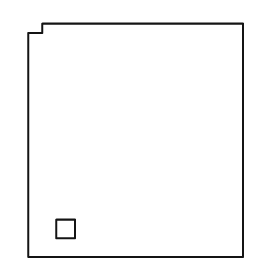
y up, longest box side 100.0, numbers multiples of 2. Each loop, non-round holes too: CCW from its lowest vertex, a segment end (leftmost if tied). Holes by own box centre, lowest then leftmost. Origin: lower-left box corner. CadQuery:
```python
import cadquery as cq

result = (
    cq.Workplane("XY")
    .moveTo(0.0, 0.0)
    .lineTo(92.0, 0.0)
    .lineTo(92.0, 100.0)
    .lineTo(6.0, 100.0)
    .lineTo(6.0, 96.0)
    .lineTo(0.0, 96.0)
    .close()
    .moveTo(12.0, 8.0)
    .lineTo(20.0, 8.0)
    .lineTo(20.0, 16.0)
    .lineTo(12.0, 16.0)
    .close()
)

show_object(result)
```